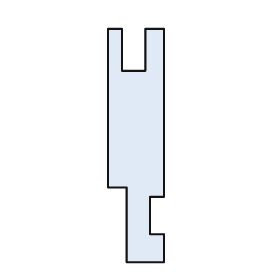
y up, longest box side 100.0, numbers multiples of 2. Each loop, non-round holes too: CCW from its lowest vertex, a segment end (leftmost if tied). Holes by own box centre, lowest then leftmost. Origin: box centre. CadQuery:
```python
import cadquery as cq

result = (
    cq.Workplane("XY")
    .moveTo(-4.0, -50.0)
    .lineTo(12.0, -50.0)
    .lineTo(12.0, -38.0)
    .lineTo(6.0, -38.0)
    .lineTo(6.0, -22.0)
    .lineTo(12.0, -22.0)
    .lineTo(12.0, 50.0)
    .lineTo(4.0, 50.0)
    .lineTo(4.0, 32.0)
    .lineTo(-6.0, 32.0)
    .lineTo(-6.0, 50.0)
    .lineTo(-12.0, 50.0)
    .lineTo(-12.0, -18.0)
    .lineTo(-4.0, -18.0)
    .close()
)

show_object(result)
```